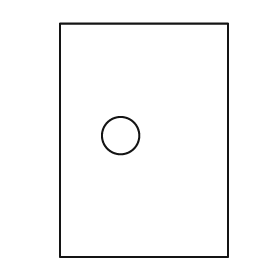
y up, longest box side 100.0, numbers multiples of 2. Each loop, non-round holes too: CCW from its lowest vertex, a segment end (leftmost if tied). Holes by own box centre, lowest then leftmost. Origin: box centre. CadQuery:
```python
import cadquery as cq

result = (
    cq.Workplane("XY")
    .moveTo(-36.0, -50.0)
    .lineTo(36.0, -50.0)
    .lineTo(36.0, 50.0)
    .lineTo(-36.0, 50.0)
    .close()
    .moveTo(-10.0, 2.0)
    .circle(8.0)
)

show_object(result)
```